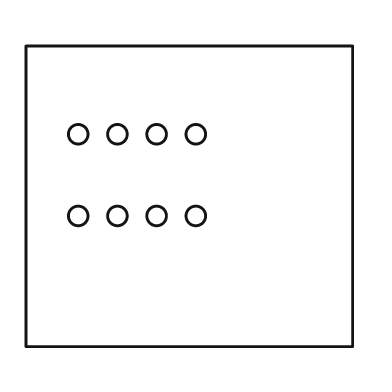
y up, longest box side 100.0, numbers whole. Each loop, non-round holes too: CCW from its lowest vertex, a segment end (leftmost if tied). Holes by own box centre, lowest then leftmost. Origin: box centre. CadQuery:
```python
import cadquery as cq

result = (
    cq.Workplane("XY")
    .moveTo(-50.0, -46.0)
    .lineTo(50.0, -46.0)
    .lineTo(50.0, 46.0)
    .lineTo(-50.0, 46.0)
    .close()
    .moveTo(-34.0, -6.0)
    .circle(3.0)
    .moveTo(-22.0, -6.0)
    .circle(3.0)
    .moveTo(-10.0, -6.0)
    .circle(3.0)
    .moveTo(2.0, -6.0)
    .circle(3.0)
    .moveTo(-34.0, 19.0)
    .circle(3.0)
    .moveTo(-22.0, 19.0)
    .circle(3.0)
    .moveTo(-10.0, 19.0)
    .circle(3.0)
    .moveTo(2.0, 19.0)
    .circle(3.0)
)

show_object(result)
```